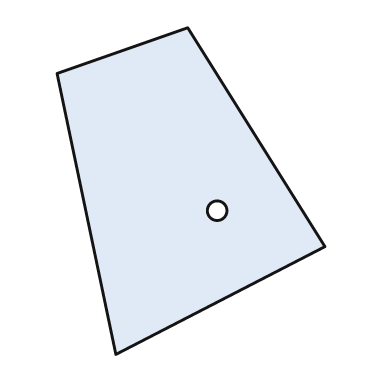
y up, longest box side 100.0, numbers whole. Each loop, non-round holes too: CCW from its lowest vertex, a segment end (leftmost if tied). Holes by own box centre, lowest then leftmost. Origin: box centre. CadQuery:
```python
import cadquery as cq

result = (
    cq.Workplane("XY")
    .moveTo(-23.0, -50.0)
    .lineTo(41.0, -17.0)
    .lineTo(-1.0, 50.0)
    .lineTo(-41.0, 36.0)
    .close()
    .moveTo(8.0, -6.0)
    .circle(3.0)
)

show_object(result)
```